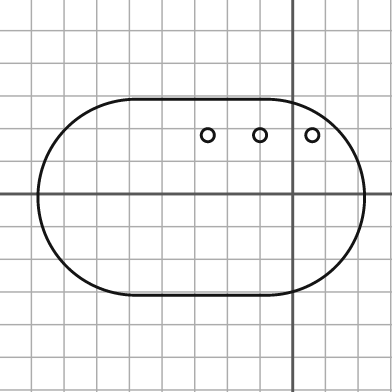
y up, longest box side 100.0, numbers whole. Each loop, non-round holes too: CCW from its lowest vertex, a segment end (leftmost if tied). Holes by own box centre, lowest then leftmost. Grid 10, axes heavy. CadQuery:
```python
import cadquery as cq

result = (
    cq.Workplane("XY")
    .moveTo(-48.0, -31.0)
    .lineTo(-8.0, -31.0)
    .threePointArc((22.0, -1.0), (-8.0, 29.0))
    .lineTo(-48.0, 29.0)
    .threePointArc((-78.0, -1.0), (-48.0, -31.0))
    .close()
    .moveTo(-26.0, 18.0)
    .circle(2.0)
    .moveTo(-10.0, 18.0)
    .circle(2.0)
    .moveTo(6.0, 18.0)
    .circle(2.0)
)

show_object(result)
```